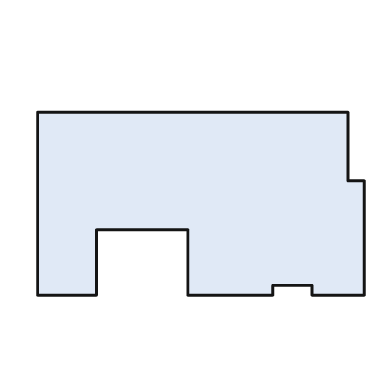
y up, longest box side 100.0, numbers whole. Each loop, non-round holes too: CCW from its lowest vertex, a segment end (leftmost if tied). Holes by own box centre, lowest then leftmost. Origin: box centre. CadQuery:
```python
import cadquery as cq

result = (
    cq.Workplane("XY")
    .moveTo(-50.0, -28.0)
    .lineTo(-32.0, -28.0)
    .lineTo(-32.0, -8.0)
    .lineTo(-4.0, -8.0)
    .lineTo(-4.0, -28.0)
    .lineTo(22.0, -28.0)
    .lineTo(22.0, -25.0)
    .lineTo(34.0, -25.0)
    .lineTo(34.0, -28.0)
    .lineTo(50.0, -28.0)
    .lineTo(50.0, 7.0)
    .lineTo(45.0, 7.0)
    .lineTo(45.0, 28.0)
    .lineTo(-50.0, 28.0)
    .close()
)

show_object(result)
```